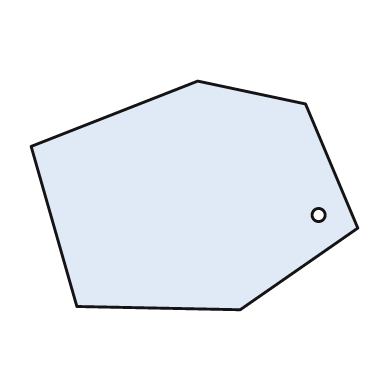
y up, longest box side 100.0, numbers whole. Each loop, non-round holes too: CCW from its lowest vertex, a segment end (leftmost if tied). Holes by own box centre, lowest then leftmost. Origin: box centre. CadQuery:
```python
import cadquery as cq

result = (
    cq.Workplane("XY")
    .moveTo(14.0, -35.0)
    .lineTo(50.0, -10.0)
    .lineTo(34.0, 28.0)
    .lineTo(1.0, 35.0)
    .lineTo(-50.0, 15.0)
    .lineTo(-36.0, -34.0)
    .close()
    .moveTo(38.0, -6.0)
    .circle(2.0)
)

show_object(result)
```